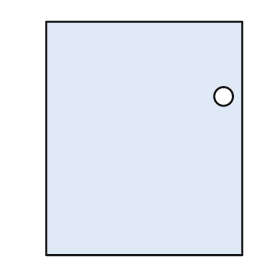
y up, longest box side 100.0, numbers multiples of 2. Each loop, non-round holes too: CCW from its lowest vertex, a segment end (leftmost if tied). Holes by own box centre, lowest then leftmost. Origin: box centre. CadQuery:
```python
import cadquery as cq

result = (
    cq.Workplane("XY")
    .moveTo(-42.0, -50.0)
    .lineTo(42.0, -50.0)
    .lineTo(42.0, 50.0)
    .lineTo(-42.0, 50.0)
    .close()
    .moveTo(34.0, 18.0)
    .circle(4.0)
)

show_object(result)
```